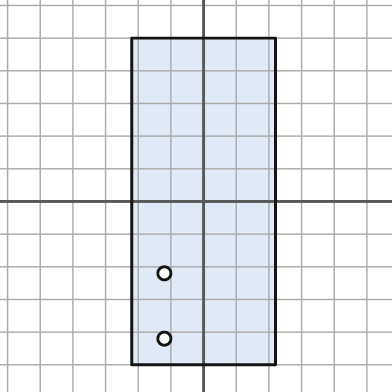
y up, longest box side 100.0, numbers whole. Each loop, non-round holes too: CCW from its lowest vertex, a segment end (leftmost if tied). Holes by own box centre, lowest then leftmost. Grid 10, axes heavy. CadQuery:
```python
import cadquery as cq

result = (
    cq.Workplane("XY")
    .moveTo(-22.0, -50.0)
    .lineTo(22.0, -50.0)
    .lineTo(22.0, 50.0)
    .lineTo(-22.0, 50.0)
    .close()
    .moveTo(-12.0, -42.0)
    .circle(2.0)
    .moveTo(-12.0, -22.0)
    .circle(2.0)
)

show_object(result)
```